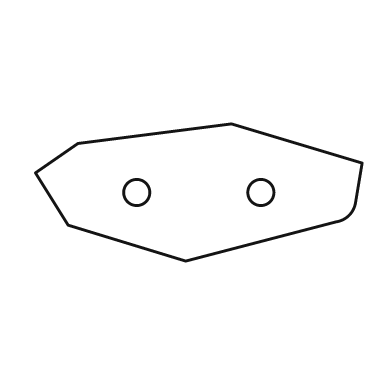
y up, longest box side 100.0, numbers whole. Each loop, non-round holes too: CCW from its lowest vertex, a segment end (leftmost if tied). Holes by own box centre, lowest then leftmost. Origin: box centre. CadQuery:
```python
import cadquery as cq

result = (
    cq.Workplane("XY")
    .moveTo(-4.0, -21.0)
    .lineTo(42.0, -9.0)
    .threePointArc((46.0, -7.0), (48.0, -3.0))
    .lineTo(50.0, 9.0)
    .lineTo(10.0, 21.0)
    .lineTo(-37.0, 15.0)
    .lineTo(-50.0, 6.0)
    .lineTo(-40.0, -10.0)
    .close()
    .moveTo(-19.0, 0.0)
    .circle(4.0)
    .moveTo(19.0, 0.0)
    .circle(4.0)
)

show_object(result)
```